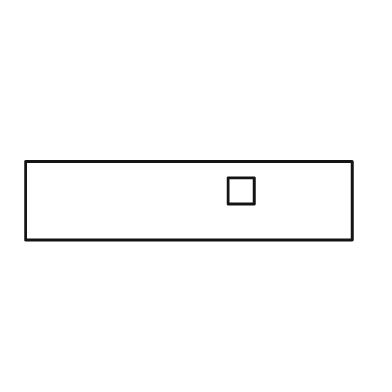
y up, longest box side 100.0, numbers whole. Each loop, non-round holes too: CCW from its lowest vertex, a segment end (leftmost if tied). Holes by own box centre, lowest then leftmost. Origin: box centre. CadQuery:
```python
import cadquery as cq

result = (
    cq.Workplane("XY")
    .moveTo(-50.0, -12.0)
    .lineTo(50.0, -12.0)
    .lineTo(50.0, 12.0)
    .lineTo(-50.0, 12.0)
    .close()
    .moveTo(12.0, -1.0)
    .lineTo(20.0, -1.0)
    .lineTo(20.0, 7.0)
    .lineTo(12.0, 7.0)
    .close()
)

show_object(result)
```